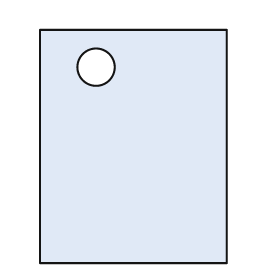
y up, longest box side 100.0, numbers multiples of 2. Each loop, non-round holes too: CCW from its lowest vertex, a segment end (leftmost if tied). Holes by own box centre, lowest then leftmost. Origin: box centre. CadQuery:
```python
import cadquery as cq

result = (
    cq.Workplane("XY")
    .moveTo(-40.0, -50.0)
    .lineTo(40.0, -50.0)
    .lineTo(40.0, 50.0)
    .lineTo(-40.0, 50.0)
    .close()
    .moveTo(-16.0, 34.0)
    .circle(8.0)
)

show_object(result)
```